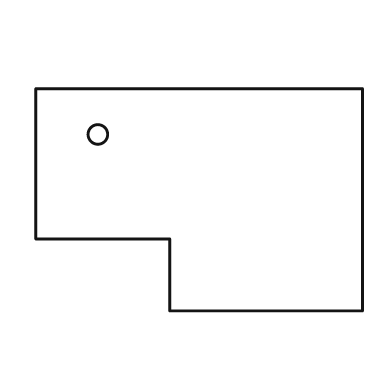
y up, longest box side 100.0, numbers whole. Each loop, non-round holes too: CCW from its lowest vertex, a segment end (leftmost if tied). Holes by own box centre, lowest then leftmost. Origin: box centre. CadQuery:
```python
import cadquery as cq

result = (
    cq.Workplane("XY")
    .moveTo(-9.0, -34.0)
    .lineTo(50.0, -34.0)
    .lineTo(50.0, 34.0)
    .lineTo(-50.0, 34.0)
    .lineTo(-50.0, -12.0)
    .lineTo(-9.0, -12.0)
    .close()
    .moveTo(-31.0, 20.0)
    .circle(3.0)
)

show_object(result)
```